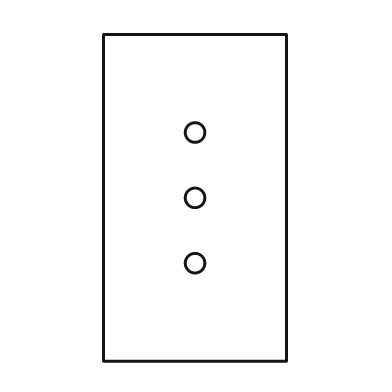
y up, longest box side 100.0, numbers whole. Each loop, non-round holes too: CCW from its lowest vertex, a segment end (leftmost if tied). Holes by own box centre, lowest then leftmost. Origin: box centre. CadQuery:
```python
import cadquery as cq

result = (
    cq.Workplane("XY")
    .moveTo(-28.0, -50.0)
    .lineTo(28.0, -50.0)
    .lineTo(28.0, 50.0)
    .lineTo(-28.0, 50.0)
    .close()
    .moveTo(0.0, -20.0)
    .circle(3.0)
    .moveTo(0.0, 0.0)
    .circle(3.0)
    .moveTo(0.0, 20.0)
    .circle(3.0)
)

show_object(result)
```